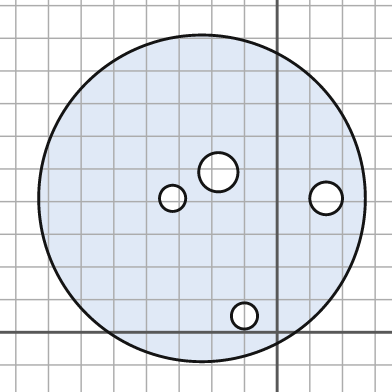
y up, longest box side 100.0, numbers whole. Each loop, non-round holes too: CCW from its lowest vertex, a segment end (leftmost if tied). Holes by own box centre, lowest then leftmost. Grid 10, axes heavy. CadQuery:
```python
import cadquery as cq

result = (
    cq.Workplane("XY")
    .moveTo(-23.0, 41.0)
    .circle(50.0)
    .moveTo(-10.0, 5.0)
    .circle(4.0)
    .moveTo(-32.0, 41.0)
    .circle(4.0)
    .moveTo(15.0, 41.0)
    .circle(5.0)
    .moveTo(-18.0, 49.0)
    .circle(6.0)
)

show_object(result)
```